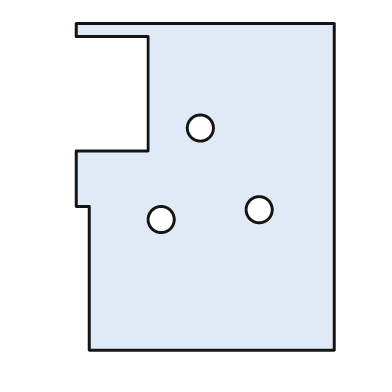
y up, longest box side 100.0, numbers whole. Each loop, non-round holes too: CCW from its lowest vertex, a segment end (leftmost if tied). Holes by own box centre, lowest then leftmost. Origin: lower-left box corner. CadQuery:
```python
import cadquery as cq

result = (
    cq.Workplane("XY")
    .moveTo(4.0, 0.0)
    .lineTo(79.0, 0.0)
    .lineTo(79.0, 100.0)
    .lineTo(0.0, 100.0)
    .lineTo(0.0, 96.0)
    .lineTo(22.0, 96.0)
    .lineTo(22.0, 61.0)
    .lineTo(0.0, 61.0)
    .lineTo(0.0, 44.0)
    .lineTo(4.0, 44.0)
    .close()
    .moveTo(26.0, 40.0)
    .circle(4.0)
    .moveTo(56.0, 43.0)
    .circle(4.0)
    .moveTo(38.0, 68.0)
    .circle(4.0)
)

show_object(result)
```